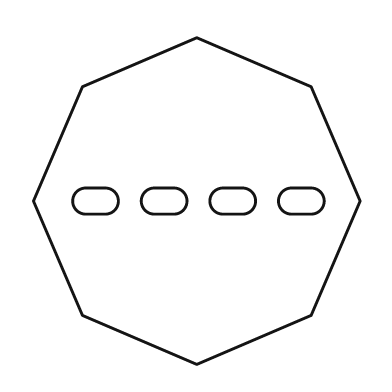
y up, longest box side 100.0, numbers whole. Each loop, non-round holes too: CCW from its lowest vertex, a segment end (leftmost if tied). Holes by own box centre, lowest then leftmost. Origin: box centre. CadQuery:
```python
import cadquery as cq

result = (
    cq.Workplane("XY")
    .moveTo(0.0, -50.0)
    .lineTo(35.0, -35.0)
    .lineTo(50.0, 0.0)
    .lineTo(35.0, 35.0)
    .lineTo(0.0, 50.0)
    .lineTo(-35.0, 35.0)
    .lineTo(-50.0, 0.0)
    .lineTo(-35.0, -35.0)
    .close()
    .moveTo(-34.0, -4.0)
    .lineTo(-28.0, -4.0)
    .threePointArc((-24.0, 0.0), (-28.0, 4.0))
    .lineTo(-34.0, 4.0)
    .threePointArc((-38.0, 0.0), (-34.0, -4.0))
    .close()
    .moveTo(-13.0, -4.0)
    .lineTo(-7.0, -4.0)
    .threePointArc((-3.0, 0.0), (-7.0, 4.0))
    .lineTo(-13.0, 4.0)
    .threePointArc((-17.0, 0.0), (-13.0, -4.0))
    .close()
    .moveTo(8.0, -4.0)
    .lineTo(14.0, -4.0)
    .threePointArc((18.0, 0.0), (14.0, 4.0))
    .lineTo(8.0, 4.0)
    .threePointArc((4.0, 0.0), (8.0, -4.0))
    .close()
    .moveTo(29.0, -4.0)
    .lineTo(35.0, -4.0)
    .threePointArc((39.0, 0.0), (35.0, 4.0))
    .lineTo(29.0, 4.0)
    .threePointArc((25.0, 0.0), (29.0, -4.0))
    .close()
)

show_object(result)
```